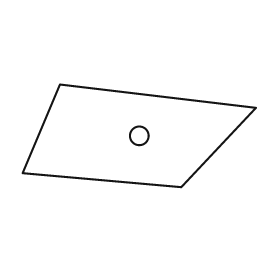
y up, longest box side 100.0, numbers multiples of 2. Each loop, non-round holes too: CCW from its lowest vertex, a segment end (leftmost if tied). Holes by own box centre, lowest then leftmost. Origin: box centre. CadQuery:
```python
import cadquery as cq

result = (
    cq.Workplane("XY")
    .moveTo(18.0, -22.0)
    .lineTo(50.0, 12.0)
    .lineTo(-34.0, 22.0)
    .lineTo(-50.0, -16.0)
    .close()
    .moveTo(0.0, 0.0)
    .circle(4.0)
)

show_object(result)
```